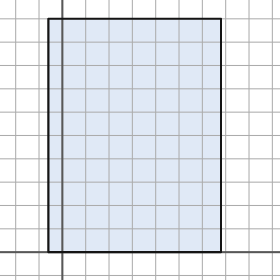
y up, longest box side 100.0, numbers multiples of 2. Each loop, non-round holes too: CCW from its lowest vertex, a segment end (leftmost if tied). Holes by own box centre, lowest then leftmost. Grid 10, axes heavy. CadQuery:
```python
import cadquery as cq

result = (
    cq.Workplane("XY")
    .moveTo(-6.0, 0.0)
    .lineTo(68.0, 0.0)
    .lineTo(68.0, 100.0)
    .lineTo(-6.0, 100.0)
    .close()
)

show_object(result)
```